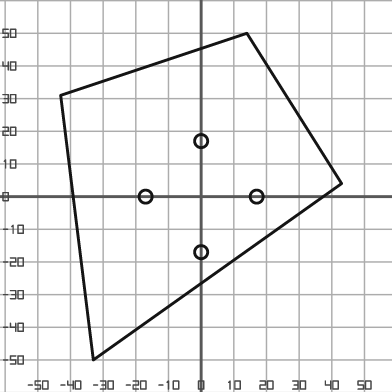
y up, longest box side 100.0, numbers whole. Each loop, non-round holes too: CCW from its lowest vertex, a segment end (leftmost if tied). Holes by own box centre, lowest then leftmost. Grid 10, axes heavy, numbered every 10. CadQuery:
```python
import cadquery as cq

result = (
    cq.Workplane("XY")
    .moveTo(-33.0, -50.0)
    .lineTo(43.0, 4.0)
    .lineTo(14.0, 50.0)
    .lineTo(-43.0, 31.0)
    .close()
    .moveTo(0.0, -17.0)
    .circle(2.0)
    .moveTo(-17.0, 0.0)
    .circle(2.0)
    .moveTo(17.0, 0.0)
    .circle(2.0)
    .moveTo(0.0, 17.0)
    .circle(2.0)
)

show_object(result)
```